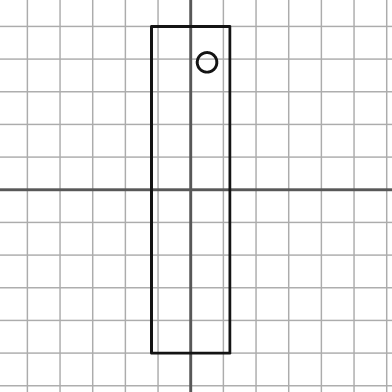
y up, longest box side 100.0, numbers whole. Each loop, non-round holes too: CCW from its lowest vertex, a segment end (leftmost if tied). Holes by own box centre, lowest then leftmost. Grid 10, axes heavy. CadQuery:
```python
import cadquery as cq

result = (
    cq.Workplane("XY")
    .moveTo(-12.0, -50.0)
    .lineTo(12.0, -50.0)
    .lineTo(12.0, 50.0)
    .lineTo(-12.0, 50.0)
    .close()
    .moveTo(5.0, 39.0)
    .circle(3.0)
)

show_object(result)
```